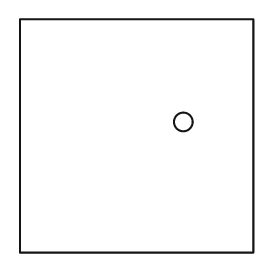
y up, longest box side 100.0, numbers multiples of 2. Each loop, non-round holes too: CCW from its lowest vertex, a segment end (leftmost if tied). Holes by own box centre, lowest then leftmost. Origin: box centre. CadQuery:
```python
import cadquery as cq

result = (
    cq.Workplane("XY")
    .moveTo(-50.0, -50.0)
    .lineTo(50.0, -50.0)
    .lineTo(50.0, 50.0)
    .lineTo(-50.0, 50.0)
    .close()
    .moveTo(20.0, 6.0)
    .circle(4.0)
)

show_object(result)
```